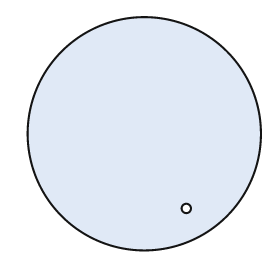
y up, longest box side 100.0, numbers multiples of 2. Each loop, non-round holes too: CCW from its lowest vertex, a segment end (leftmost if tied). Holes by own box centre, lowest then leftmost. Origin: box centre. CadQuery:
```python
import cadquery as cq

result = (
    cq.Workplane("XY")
    .moveTo(0.0, 0.0)
    .circle(50.0)
    .moveTo(18.0, -32.0)
    .circle(2.0)
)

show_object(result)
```